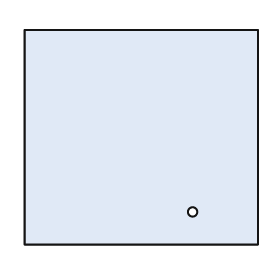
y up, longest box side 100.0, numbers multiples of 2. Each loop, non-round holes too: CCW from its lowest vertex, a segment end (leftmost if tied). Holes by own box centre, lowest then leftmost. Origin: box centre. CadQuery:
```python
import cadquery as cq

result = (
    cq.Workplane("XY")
    .moveTo(-50.0, -46.0)
    .lineTo(50.0, -46.0)
    .lineTo(50.0, 46.0)
    .lineTo(-50.0, 46.0)
    .close()
    .moveTo(22.0, -32.0)
    .circle(2.0)
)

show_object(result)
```